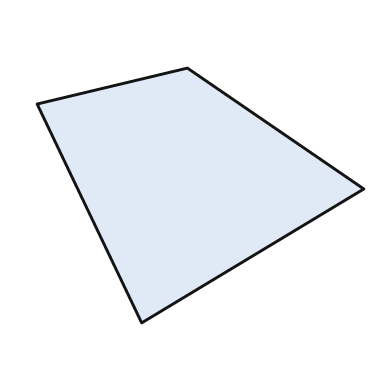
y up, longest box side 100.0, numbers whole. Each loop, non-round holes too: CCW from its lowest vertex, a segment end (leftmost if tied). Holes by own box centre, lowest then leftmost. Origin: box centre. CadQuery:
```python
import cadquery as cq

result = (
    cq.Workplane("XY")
    .moveTo(-18.0, -39.0)
    .lineTo(50.0, 2.0)
    .lineTo(-4.0, 39.0)
    .lineTo(-50.0, 28.0)
    .close()
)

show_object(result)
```